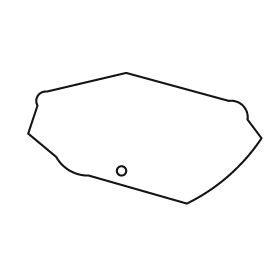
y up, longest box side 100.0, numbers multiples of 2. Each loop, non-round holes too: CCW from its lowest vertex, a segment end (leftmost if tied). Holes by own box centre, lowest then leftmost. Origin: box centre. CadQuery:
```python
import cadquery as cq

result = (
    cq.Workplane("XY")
    .moveTo(18.0, -28.0)
    .threePointArc((36.0, -16.0), (50.0, 0.0))
    .lineTo(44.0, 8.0)
    .threePointArc((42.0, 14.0), (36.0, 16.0))
    .lineTo(-8.0, 28.0)
    .lineTo(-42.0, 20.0)
    .threePointArc((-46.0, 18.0), (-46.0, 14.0))
    .lineTo(-50.0, 2.0)
    .lineTo(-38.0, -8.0)
    .threePointArc((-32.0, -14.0), (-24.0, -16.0))
    .close()
    .moveTo(-10.0, -14.0)
    .circle(2.0)
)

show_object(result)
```